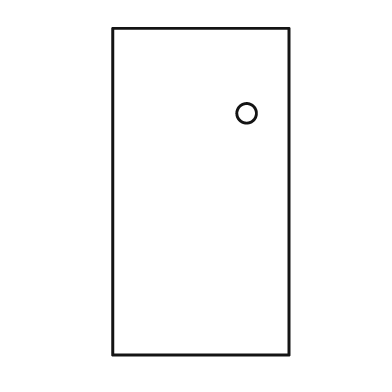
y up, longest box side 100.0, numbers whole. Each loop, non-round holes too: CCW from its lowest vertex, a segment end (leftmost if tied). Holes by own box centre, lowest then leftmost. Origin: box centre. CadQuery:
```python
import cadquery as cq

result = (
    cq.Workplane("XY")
    .moveTo(-27.0, -50.0)
    .lineTo(27.0, -50.0)
    .lineTo(27.0, 50.0)
    .lineTo(-27.0, 50.0)
    .close()
    .moveTo(14.0, 24.0)
    .circle(3.0)
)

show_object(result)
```